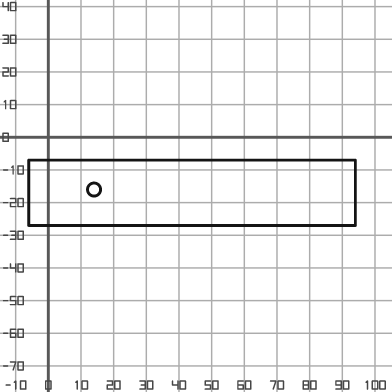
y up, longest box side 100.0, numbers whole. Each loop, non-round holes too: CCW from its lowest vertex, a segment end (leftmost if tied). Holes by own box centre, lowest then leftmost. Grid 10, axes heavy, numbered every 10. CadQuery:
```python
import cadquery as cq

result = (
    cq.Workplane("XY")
    .moveTo(-6.0, -27.0)
    .lineTo(94.0, -27.0)
    .lineTo(94.0, -7.0)
    .lineTo(-6.0, -7.0)
    .close()
    .moveTo(14.0, -16.0)
    .circle(2.0)
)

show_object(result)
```